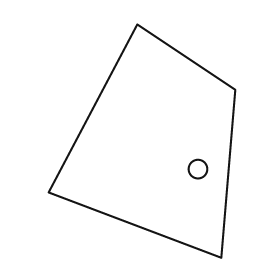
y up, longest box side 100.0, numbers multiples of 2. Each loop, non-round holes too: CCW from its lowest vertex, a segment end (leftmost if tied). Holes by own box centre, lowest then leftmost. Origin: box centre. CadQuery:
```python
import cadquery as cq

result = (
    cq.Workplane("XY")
    .moveTo(34.0, -50.0)
    .lineTo(40.0, 22.0)
    .lineTo(-2.0, 50.0)
    .lineTo(-40.0, -22.0)
    .close()
    .moveTo(24.0, -12.0)
    .circle(4.0)
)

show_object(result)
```